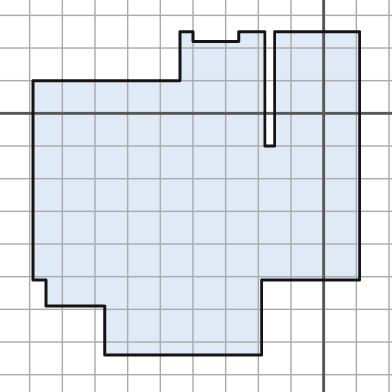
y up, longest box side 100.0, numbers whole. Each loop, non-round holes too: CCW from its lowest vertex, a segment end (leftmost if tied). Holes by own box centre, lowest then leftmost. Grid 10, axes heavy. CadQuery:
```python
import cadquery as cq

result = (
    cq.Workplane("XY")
    .moveTo(-67.0, -74.0)
    .lineTo(-19.0, -74.0)
    .lineTo(-19.0, -51.0)
    .lineTo(11.0, -51.0)
    .lineTo(11.0, 25.0)
    .lineTo(-15.0, 25.0)
    .lineTo(-15.0, -10.0)
    .lineTo(-18.0, -10.0)
    .lineTo(-18.0, 25.0)
    .lineTo(-26.0, 25.0)
    .lineTo(-26.0, 22.0)
    .lineTo(-40.0, 22.0)
    .lineTo(-40.0, 25.0)
    .lineTo(-44.0, 25.0)
    .lineTo(-44.0, 10.0)
    .lineTo(-89.0, 10.0)
    .lineTo(-89.0, -51.0)
    .lineTo(-85.0, -51.0)
    .lineTo(-85.0, -59.0)
    .lineTo(-67.0, -59.0)
    .close()
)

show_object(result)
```